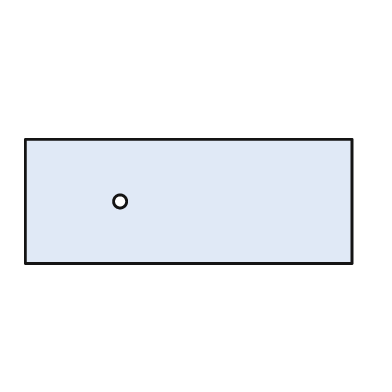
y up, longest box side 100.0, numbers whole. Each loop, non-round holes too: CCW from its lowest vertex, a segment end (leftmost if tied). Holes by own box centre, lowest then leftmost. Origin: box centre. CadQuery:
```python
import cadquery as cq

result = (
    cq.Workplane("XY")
    .moveTo(-50.0, -19.0)
    .lineTo(50.0, -19.0)
    .lineTo(50.0, 19.0)
    .lineTo(-50.0, 19.0)
    .close()
    .moveTo(-21.0, 0.0)
    .circle(2.0)
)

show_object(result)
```